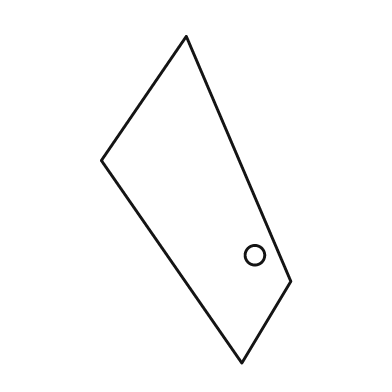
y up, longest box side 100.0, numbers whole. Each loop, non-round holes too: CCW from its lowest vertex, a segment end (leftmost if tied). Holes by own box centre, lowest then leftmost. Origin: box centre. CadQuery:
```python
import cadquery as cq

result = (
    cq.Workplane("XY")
    .moveTo(14.0, -50.0)
    .lineTo(29.0, -25.0)
    .lineTo(-3.0, 50.0)
    .lineTo(-29.0, 12.0)
    .close()
    .moveTo(18.0, -17.0)
    .circle(3.0)
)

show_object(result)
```